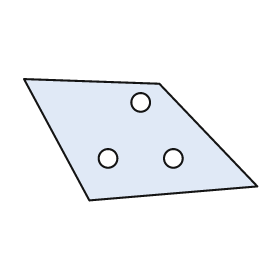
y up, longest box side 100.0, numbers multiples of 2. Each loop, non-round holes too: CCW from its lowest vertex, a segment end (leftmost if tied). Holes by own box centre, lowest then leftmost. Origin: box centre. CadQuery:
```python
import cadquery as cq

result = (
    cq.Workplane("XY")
    .moveTo(-22.0, -26.0)
    .lineTo(50.0, -20.0)
    .lineTo(8.0, 24.0)
    .lineTo(-50.0, 26.0)
    .close()
    .moveTo(-14.0, -8.0)
    .circle(4.0)
    .moveTo(14.0, -8.0)
    .circle(4.0)
    .moveTo(0.0, 16.0)
    .circle(4.0)
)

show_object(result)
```